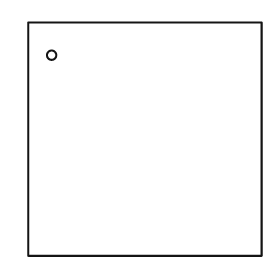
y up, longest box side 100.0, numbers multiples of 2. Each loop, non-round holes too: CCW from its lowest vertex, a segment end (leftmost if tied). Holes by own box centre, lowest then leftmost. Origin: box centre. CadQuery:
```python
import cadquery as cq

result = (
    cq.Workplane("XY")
    .moveTo(-50.0, -50.0)
    .lineTo(50.0, -50.0)
    .lineTo(50.0, 50.0)
    .lineTo(-50.0, 50.0)
    .close()
    .moveTo(-40.0, 36.0)
    .circle(2.0)
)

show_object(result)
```